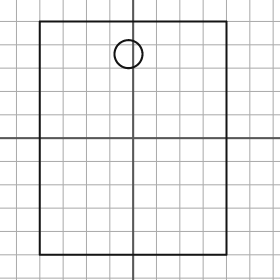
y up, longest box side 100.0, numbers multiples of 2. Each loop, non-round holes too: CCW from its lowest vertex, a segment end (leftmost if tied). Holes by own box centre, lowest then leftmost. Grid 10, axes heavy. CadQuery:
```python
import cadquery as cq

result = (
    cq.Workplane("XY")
    .moveTo(-40.0, -50.0)
    .lineTo(40.0, -50.0)
    .lineTo(40.0, 50.0)
    .lineTo(-40.0, 50.0)
    .close()
    .moveTo(-2.0, 36.0)
    .circle(6.0)
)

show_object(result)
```